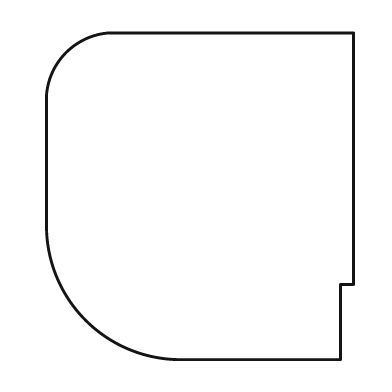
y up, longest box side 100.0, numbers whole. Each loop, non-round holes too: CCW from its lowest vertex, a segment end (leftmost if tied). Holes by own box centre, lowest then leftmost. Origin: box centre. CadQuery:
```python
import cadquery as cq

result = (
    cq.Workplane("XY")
    .moveTo(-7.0, -50.0)
    .lineTo(43.0, -50.0)
    .lineTo(43.0, -27.0)
    .lineTo(47.0, -27.0)
    .lineTo(47.0, 50.0)
    .lineTo(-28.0, 50.0)
    .threePointArc((-41.0, 44.0), (-47.0, 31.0))
    .lineTo(-47.0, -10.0)
    .threePointArc((-35.0, -38.0), (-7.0, -50.0))
    .close()
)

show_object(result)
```